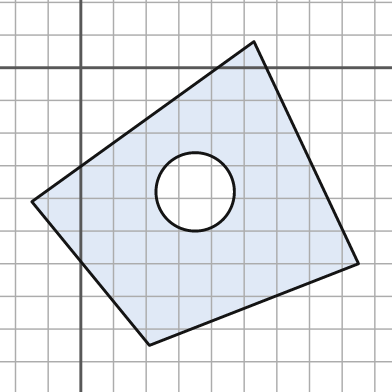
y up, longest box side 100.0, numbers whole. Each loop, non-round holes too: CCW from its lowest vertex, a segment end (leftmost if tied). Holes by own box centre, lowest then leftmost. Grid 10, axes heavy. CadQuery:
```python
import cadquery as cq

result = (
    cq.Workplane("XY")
    .moveTo(21.0, -85.0)
    .lineTo(85.0, -60.0)
    .lineTo(53.0, 8.0)
    .lineTo(-15.0, -41.0)
    .close()
    .moveTo(35.0, -38.0)
    .circle(12.0)
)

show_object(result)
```